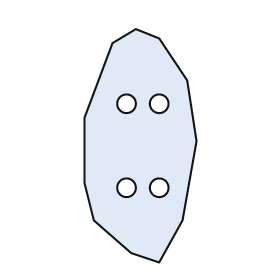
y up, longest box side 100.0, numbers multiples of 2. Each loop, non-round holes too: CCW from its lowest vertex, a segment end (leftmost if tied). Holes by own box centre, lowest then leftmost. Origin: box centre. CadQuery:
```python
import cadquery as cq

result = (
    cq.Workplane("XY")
    .moveTo(8.0, -50.0)
    .lineTo(18.0, -32.0)
    .lineTo(24.0, 2.0)
    .lineTo(20.0, 28.0)
    .lineTo(8.0, 46.0)
    .lineTo(-2.0, 50.0)
    .lineTo(-12.0, 44.0)
    .lineTo(-24.0, 12.0)
    .lineTo(-24.0, -16.0)
    .lineTo(-20.0, -32.0)
    .lineTo(-4.0, -46.0)
    .close()
    .moveTo(-6.0, -18.0)
    .circle(4.0)
    .moveTo(8.0, -18.0)
    .circle(4.0)
    .moveTo(-6.0, 18.0)
    .circle(4.0)
    .moveTo(8.0, 18.0)
    .circle(4.0)
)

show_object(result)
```